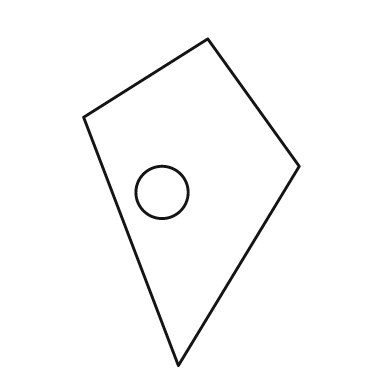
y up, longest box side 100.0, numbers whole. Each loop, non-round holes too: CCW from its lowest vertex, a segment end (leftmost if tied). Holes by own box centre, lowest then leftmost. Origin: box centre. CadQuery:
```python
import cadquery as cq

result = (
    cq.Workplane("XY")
    .moveTo(-4.0, -50.0)
    .lineTo(33.0, 11.0)
    .lineTo(5.0, 50.0)
    .lineTo(-33.0, 26.0)
    .close()
    .moveTo(-9.0, 3.0)
    .circle(8.0)
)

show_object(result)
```